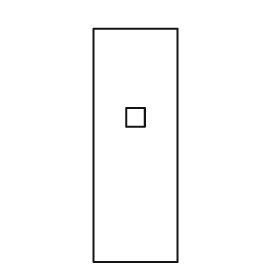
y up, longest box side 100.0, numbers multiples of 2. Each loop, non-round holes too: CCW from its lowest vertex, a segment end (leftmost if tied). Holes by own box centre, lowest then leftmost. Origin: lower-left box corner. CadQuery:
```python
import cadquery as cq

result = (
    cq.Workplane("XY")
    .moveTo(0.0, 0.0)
    .lineTo(36.0, 0.0)
    .lineTo(36.0, 100.0)
    .lineTo(0.0, 100.0)
    .close()
    .moveTo(14.0, 58.0)
    .lineTo(22.0, 58.0)
    .lineTo(22.0, 66.0)
    .lineTo(14.0, 66.0)
    .close()
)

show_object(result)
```